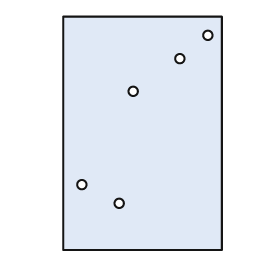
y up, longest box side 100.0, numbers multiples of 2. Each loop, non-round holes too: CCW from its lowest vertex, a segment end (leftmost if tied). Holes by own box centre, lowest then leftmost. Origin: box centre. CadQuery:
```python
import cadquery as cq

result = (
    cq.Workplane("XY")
    .moveTo(-34.0, -50.0)
    .lineTo(34.0, -50.0)
    .lineTo(34.0, 50.0)
    .lineTo(-34.0, 50.0)
    .close()
    .moveTo(-10.0, -30.0)
    .circle(2.0)
    .moveTo(-26.0, -22.0)
    .circle(2.0)
    .moveTo(-4.0, 18.0)
    .circle(2.0)
    .moveTo(16.0, 32.0)
    .circle(2.0)
    .moveTo(28.0, 42.0)
    .circle(2.0)
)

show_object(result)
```